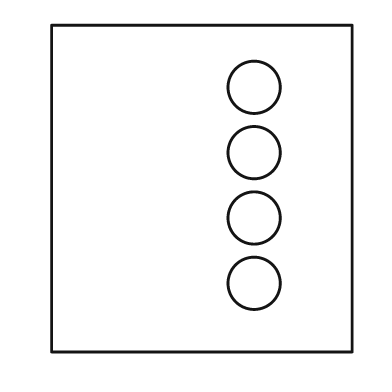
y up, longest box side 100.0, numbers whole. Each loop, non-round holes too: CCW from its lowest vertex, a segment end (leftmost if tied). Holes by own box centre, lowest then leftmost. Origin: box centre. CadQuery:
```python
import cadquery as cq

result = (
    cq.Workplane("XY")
    .moveTo(-46.0, -50.0)
    .lineTo(46.0, -50.0)
    .lineTo(46.0, 50.0)
    .lineTo(-46.0, 50.0)
    .close()
    .moveTo(16.0, -29.0)
    .circle(8.0)
    .moveTo(16.0, -9.0)
    .circle(8.0)
    .moveTo(16.0, 11.0)
    .circle(8.0)
    .moveTo(16.0, 31.0)
    .circle(8.0)
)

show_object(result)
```